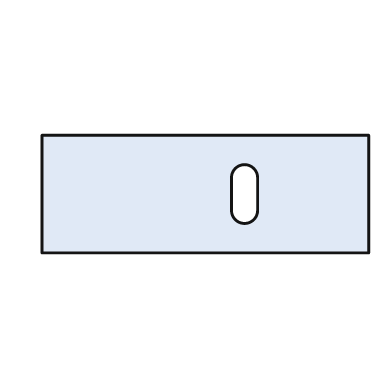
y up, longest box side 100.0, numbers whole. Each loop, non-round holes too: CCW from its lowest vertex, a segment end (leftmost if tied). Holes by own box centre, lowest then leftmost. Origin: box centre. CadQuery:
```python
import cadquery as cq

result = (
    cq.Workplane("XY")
    .moveTo(-50.0, -18.0)
    .lineTo(50.0, -18.0)
    .lineTo(50.0, 18.0)
    .lineTo(-50.0, 18.0)
    .close()
    .moveTo(8.0, -5.0)
    .threePointArc((12.0, -9.0), (16.0, -5.0))
    .lineTo(16.0, 5.0)
    .threePointArc((12.0, 9.0), (8.0, 5.0))
    .close()
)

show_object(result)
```